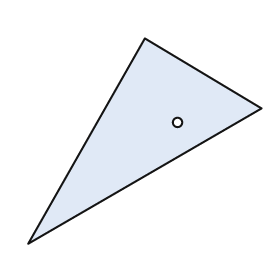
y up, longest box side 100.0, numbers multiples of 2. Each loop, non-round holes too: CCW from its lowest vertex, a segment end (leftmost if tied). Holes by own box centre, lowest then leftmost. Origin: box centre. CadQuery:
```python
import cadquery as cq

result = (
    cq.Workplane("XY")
    .moveTo(-50.0, -44.0)
    .lineTo(50.0, 14.0)
    .lineTo(0.0, 44.0)
    .close()
    .moveTo(14.0, 8.0)
    .circle(2.0)
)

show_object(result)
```